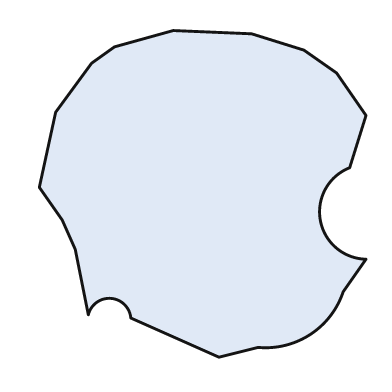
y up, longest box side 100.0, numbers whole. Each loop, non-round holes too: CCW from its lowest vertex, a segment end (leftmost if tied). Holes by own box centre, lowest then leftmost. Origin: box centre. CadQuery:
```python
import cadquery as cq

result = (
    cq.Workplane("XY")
    .moveTo(5.0, -50.0)
    .lineTo(17.0, -47.0)
    .threePointArc((33.0, -43.0), (43.0, -30.0))
    .lineTo(50.0, -20.0)
    .threePointArc((36.0, -8.0), (45.0, 8.0))
    .lineTo(50.0, 24.0)
    .lineTo(41.0, 37.0)
    .lineTo(31.0, 44.0)
    .lineTo(15.0, 49.0)
    .lineTo(-9.0, 50.0)
    .lineTo(-27.0, 45.0)
    .lineTo(-34.0, 40.0)
    .lineTo(-45.0, 25.0)
    .lineTo(-50.0, 2.0)
    .lineTo(-43.0, -8.0)
    .lineTo(-39.0, -17.0)
    .lineTo(-35.0, -37.0)
    .threePointArc((-28.0, -32.0), (-22.0, -38.0))
    .close()
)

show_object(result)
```